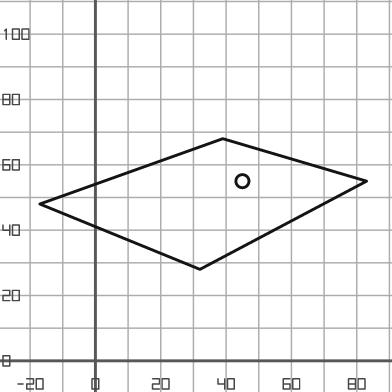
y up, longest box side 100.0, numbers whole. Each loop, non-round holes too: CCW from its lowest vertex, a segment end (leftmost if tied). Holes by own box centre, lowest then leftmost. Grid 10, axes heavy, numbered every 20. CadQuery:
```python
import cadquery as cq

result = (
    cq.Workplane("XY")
    .moveTo(32.0, 28.0)
    .lineTo(83.0, 55.0)
    .lineTo(39.0, 68.0)
    .lineTo(-17.0, 48.0)
    .close()
    .moveTo(45.0, 55.0)
    .circle(2.0)
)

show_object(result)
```